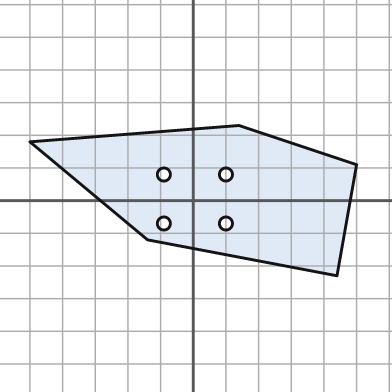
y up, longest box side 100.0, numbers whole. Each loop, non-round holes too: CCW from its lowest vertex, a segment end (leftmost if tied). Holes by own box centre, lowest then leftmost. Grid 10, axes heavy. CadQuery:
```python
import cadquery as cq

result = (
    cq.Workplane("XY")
    .moveTo(44.0, -23.0)
    .lineTo(50.0, 11.0)
    .lineTo(14.0, 23.0)
    .lineTo(-50.0, 18.0)
    .lineTo(-14.0, -12.0)
    .close()
    .moveTo(-9.0, -7.0)
    .circle(2.0)
    .moveTo(10.0, -7.0)
    .circle(2.0)
    .moveTo(-9.0, 8.0)
    .circle(2.0)
    .moveTo(10.0, 8.0)
    .circle(2.0)
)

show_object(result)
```